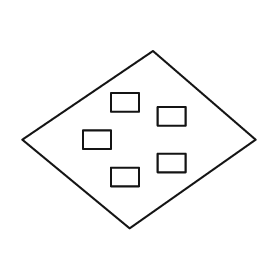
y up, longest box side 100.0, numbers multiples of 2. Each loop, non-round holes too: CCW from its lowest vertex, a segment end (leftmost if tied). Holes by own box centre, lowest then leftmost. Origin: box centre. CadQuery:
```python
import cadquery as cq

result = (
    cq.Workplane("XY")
    .moveTo(-4.0, -38.0)
    .lineTo(50.0, 0.0)
    .lineTo(6.0, 38.0)
    .lineTo(-50.0, 0.0)
    .close()
    .moveTo(-12.0, -20.0)
    .lineTo(0.0, -20.0)
    .lineTo(0.0, -12.0)
    .lineTo(-12.0, -12.0)
    .close()
    .moveTo(8.0, -14.0)
    .lineTo(20.0, -14.0)
    .lineTo(20.0, -6.0)
    .lineTo(8.0, -6.0)
    .close()
    .moveTo(-24.0, -4.0)
    .lineTo(-12.0, -4.0)
    .lineTo(-12.0, 4.0)
    .lineTo(-24.0, 4.0)
    .close()
    .moveTo(8.0, 6.0)
    .lineTo(20.0, 6.0)
    .lineTo(20.0, 14.0)
    .lineTo(8.0, 14.0)
    .close()
    .moveTo(-12.0, 12.0)
    .lineTo(0.0, 12.0)
    .lineTo(0.0, 20.0)
    .lineTo(-12.0, 20.0)
    .close()
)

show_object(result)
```